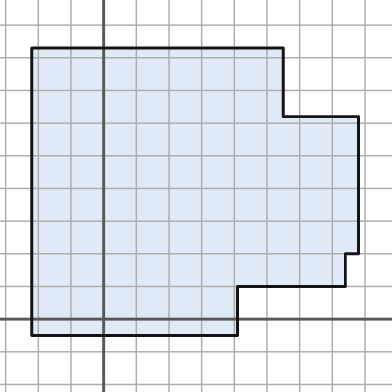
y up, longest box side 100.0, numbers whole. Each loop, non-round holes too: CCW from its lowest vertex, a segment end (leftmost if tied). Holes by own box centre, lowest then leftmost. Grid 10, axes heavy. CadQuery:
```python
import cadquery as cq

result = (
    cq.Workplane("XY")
    .moveTo(-22.0, -5.0)
    .lineTo(41.0, -5.0)
    .lineTo(41.0, 10.0)
    .lineTo(74.0, 10.0)
    .lineTo(74.0, 20.0)
    .lineTo(78.0, 20.0)
    .lineTo(78.0, 62.0)
    .lineTo(55.0, 62.0)
    .lineTo(55.0, 83.0)
    .lineTo(-22.0, 83.0)
    .close()
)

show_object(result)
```